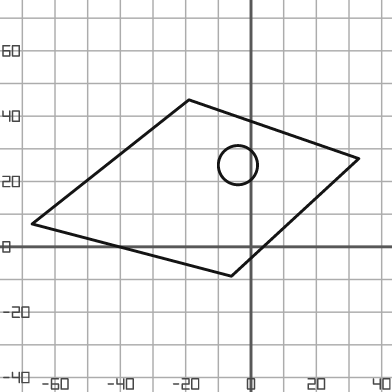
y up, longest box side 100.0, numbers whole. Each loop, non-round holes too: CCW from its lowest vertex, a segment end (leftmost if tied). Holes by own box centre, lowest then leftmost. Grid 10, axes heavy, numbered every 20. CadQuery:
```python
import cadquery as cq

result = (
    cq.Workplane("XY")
    .moveTo(-6.0, -9.0)
    .lineTo(33.0, 27.0)
    .lineTo(-19.0, 45.0)
    .lineTo(-67.0, 7.0)
    .close()
    .moveTo(-4.0, 25.0)
    .circle(6.0)
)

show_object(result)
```